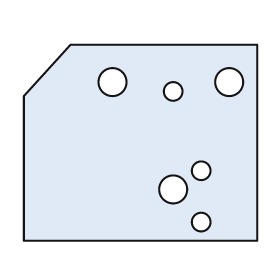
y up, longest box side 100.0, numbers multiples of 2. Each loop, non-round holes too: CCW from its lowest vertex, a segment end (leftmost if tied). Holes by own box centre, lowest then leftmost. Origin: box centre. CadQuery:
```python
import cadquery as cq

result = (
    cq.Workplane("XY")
    .moveTo(-50.0, -42.0)
    .lineTo(50.0, -42.0)
    .lineTo(50.0, 42.0)
    .lineTo(-30.0, 42.0)
    .lineTo(-50.0, 20.0)
    .close()
    .moveTo(26.0, -34.0)
    .circle(4.0)
    .moveTo(14.0, -20.0)
    .circle(6.0)
    .moveTo(26.0, -12.0)
    .circle(4.0)
    .moveTo(14.0, 22.0)
    .circle(4.0)
    .moveTo(-12.0, 26.0)
    .circle(6.0)
    .moveTo(38.0, 26.0)
    .circle(6.0)
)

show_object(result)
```